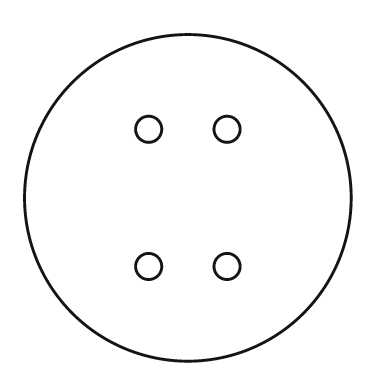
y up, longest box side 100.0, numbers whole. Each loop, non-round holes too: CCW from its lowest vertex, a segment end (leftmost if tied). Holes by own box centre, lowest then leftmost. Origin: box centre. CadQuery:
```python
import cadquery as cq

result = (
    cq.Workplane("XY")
    .moveTo(0.0, 0.0)
    .circle(50.0)
    .moveTo(-12.0, -21.0)
    .circle(4.0)
    .moveTo(12.0, -21.0)
    .circle(4.0)
    .moveTo(-12.0, 21.0)
    .circle(4.0)
    .moveTo(12.0, 21.0)
    .circle(4.0)
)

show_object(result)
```